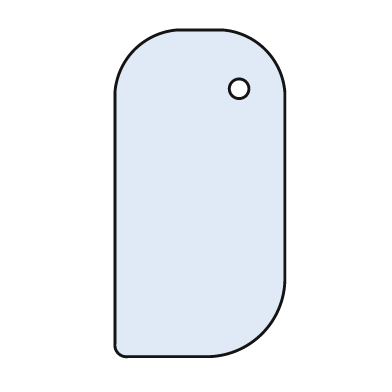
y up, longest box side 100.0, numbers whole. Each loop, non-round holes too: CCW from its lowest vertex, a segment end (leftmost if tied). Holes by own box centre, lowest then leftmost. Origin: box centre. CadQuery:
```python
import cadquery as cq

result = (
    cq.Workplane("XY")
    .moveTo(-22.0, -50.0)
    .lineTo(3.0, -50.0)
    .threePointArc((19.0, -43.0), (26.0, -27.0))
    .lineTo(26.0, 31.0)
    .threePointArc((20.0, 44.0), (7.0, 50.0))
    .lineTo(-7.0, 50.0)
    .threePointArc((-20.0, 44.0), (-26.0, 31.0))
    .lineTo(-26.0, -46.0)
    .threePointArc((-25.0, -49.0), (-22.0, -50.0))
    .close()
    .moveTo(12.0, 32.0)
    .circle(3.0)
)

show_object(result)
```